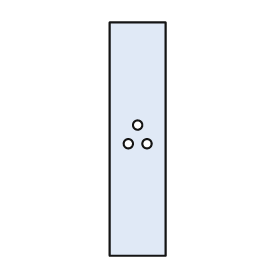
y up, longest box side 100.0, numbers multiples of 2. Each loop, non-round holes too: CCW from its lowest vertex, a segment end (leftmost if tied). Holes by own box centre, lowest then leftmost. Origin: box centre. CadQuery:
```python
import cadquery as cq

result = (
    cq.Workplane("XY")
    .moveTo(-12.0, -50.0)
    .lineTo(12.0, -50.0)
    .lineTo(12.0, 50.0)
    .lineTo(-12.0, 50.0)
    .close()
    .moveTo(-4.0, -2.0)
    .circle(2.0)
    .moveTo(4.0, -2.0)
    .circle(2.0)
    .moveTo(0.0, 6.0)
    .circle(2.0)
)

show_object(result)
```